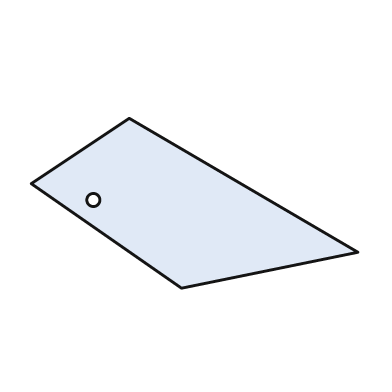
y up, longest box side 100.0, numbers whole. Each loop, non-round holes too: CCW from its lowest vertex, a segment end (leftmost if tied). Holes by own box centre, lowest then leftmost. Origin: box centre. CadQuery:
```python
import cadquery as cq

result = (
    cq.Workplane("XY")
    .moveTo(-4.0, -26.0)
    .lineTo(50.0, -15.0)
    .lineTo(-20.0, 26.0)
    .lineTo(-50.0, 6.0)
    .close()
    .moveTo(-31.0, 1.0)
    .circle(2.0)
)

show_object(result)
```